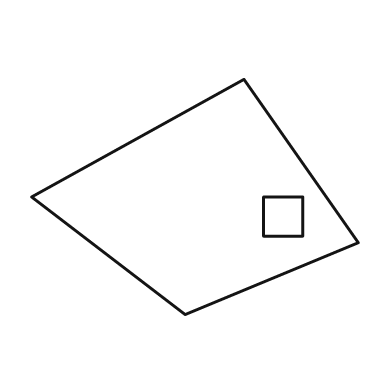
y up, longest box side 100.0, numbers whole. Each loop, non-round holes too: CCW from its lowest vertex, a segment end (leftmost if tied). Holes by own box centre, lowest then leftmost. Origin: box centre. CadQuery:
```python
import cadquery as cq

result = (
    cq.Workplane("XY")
    .moveTo(-3.0, -36.0)
    .lineTo(50.0, -14.0)
    .lineTo(15.0, 36.0)
    .lineTo(-50.0, 0.0)
    .close()
    .moveTo(21.0, -12.0)
    .lineTo(33.0, -12.0)
    .lineTo(33.0, 0.0)
    .lineTo(21.0, 0.0)
    .close()
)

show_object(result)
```